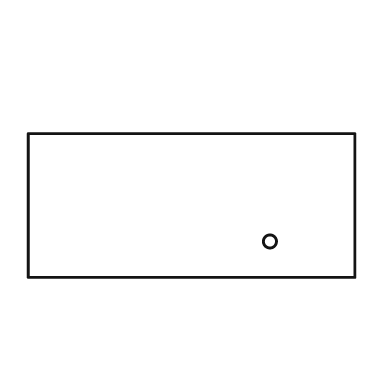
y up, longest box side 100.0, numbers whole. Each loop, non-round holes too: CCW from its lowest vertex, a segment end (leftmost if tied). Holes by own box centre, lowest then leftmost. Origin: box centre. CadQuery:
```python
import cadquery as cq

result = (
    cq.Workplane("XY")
    .moveTo(-50.0, -22.0)
    .lineTo(50.0, -22.0)
    .lineTo(50.0, 22.0)
    .lineTo(-50.0, 22.0)
    .close()
    .moveTo(24.0, -11.0)
    .circle(2.0)
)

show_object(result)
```